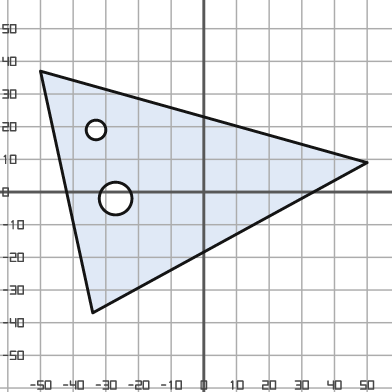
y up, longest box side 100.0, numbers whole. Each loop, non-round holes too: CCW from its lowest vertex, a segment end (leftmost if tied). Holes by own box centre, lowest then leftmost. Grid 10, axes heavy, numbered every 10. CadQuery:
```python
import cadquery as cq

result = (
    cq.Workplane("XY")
    .moveTo(-34.0, -37.0)
    .lineTo(50.0, 9.0)
    .lineTo(-50.0, 37.0)
    .close()
    .moveTo(-27.0, -2.0)
    .circle(5.0)
    .moveTo(-33.0, 19.0)
    .circle(3.0)
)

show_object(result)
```